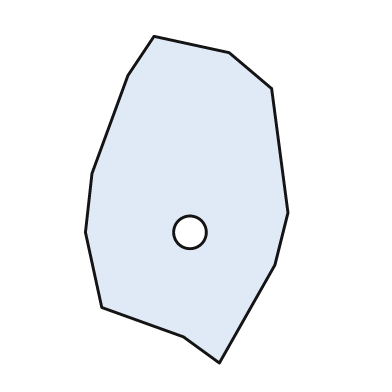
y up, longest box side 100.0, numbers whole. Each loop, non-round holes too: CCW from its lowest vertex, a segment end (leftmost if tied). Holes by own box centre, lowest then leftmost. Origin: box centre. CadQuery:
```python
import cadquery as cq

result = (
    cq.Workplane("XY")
    .moveTo(10.0, -50.0)
    .lineTo(27.0, -20.0)
    .lineTo(31.0, -4.0)
    .lineTo(26.0, 34.0)
    .lineTo(13.0, 45.0)
    .lineTo(-10.0, 50.0)
    .lineTo(-18.0, 38.0)
    .lineTo(-29.0, 8.0)
    .lineTo(-31.0, -10.0)
    .lineTo(-26.0, -33.0)
    .lineTo(-1.0, -42.0)
    .close()
    .moveTo(1.0, -10.0)
    .circle(5.0)
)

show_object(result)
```